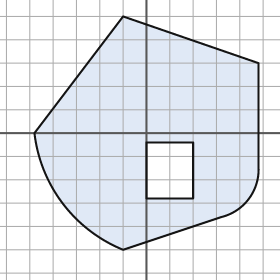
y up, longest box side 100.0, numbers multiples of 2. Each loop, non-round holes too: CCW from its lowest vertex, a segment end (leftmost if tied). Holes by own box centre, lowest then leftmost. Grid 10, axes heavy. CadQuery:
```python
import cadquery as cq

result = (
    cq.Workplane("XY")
    .moveTo(-10.0, -50.0)
    .lineTo(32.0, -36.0)
    .threePointArc((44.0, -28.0), (48.0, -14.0))
    .lineTo(48.0, 30.0)
    .lineTo(-10.0, 50.0)
    .lineTo(-48.0, 0.0)
    .threePointArc((-36.0, -30.0), (-10.0, -50.0))
    .close()
    .moveTo(0.0, -28.0)
    .lineTo(20.0, -28.0)
    .lineTo(20.0, -4.0)
    .lineTo(0.0, -4.0)
    .close()
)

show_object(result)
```